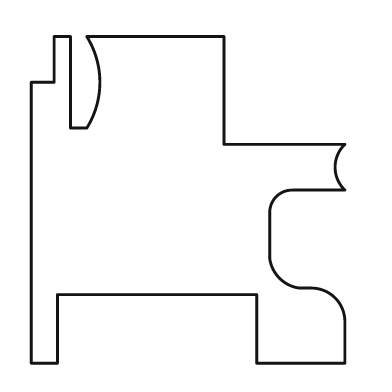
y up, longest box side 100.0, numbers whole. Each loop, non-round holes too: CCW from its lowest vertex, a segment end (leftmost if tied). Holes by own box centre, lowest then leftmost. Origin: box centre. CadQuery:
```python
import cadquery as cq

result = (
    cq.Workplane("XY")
    .moveTo(-48.0, -50.0)
    .lineTo(-40.0, -50.0)
    .lineTo(-40.0, -29.0)
    .lineTo(21.0, -29.0)
    .lineTo(21.0, -50.0)
    .lineTo(48.0, -50.0)
    .lineTo(48.0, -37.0)
    .threePointArc((45.0, -30.0), (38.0, -27.0))
    .lineTo(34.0, -27.0)
    .threePointArc((28.0, -24.0), (25.0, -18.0))
    .lineTo(25.0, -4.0)
    .threePointArc((27.0, 1.0), (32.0, 3.0))
    .lineTo(48.0, 3.0)
    .threePointArc((45.0, 10.0), (48.0, 17.0))
    .lineTo(11.0, 17.0)
    .lineTo(11.0, 50.0)
    .lineTo(-31.0, 50.0)
    .threePointArc((-27.0, 36.0), (-31.0, 22.0))
    .lineTo(-36.0, 22.0)
    .lineTo(-36.0, 50.0)
    .lineTo(-41.0, 50.0)
    .lineTo(-41.0, 36.0)
    .lineTo(-48.0, 36.0)
    .close()
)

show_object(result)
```